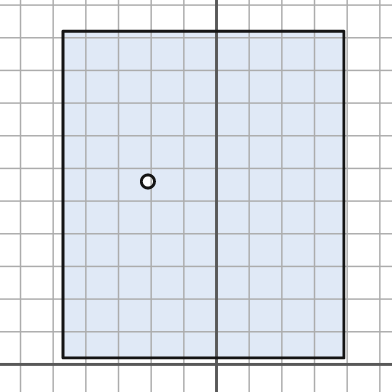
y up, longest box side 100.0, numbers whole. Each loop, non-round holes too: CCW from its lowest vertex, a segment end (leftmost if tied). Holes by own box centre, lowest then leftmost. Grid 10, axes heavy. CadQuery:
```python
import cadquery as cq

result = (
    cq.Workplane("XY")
    .moveTo(-47.0, 2.0)
    .lineTo(39.0, 2.0)
    .lineTo(39.0, 102.0)
    .lineTo(-47.0, 102.0)
    .close()
    .moveTo(-21.0, 56.0)
    .circle(2.0)
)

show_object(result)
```